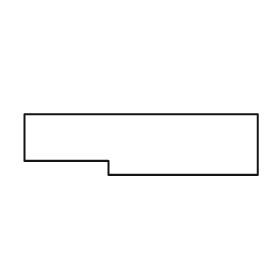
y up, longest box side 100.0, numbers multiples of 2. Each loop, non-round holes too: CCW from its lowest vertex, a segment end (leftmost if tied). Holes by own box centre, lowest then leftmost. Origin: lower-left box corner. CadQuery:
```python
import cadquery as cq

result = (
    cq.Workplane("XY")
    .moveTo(36.0, 0.0)
    .lineTo(100.0, 0.0)
    .lineTo(100.0, 26.0)
    .lineTo(0.0, 26.0)
    .lineTo(0.0, 6.0)
    .lineTo(36.0, 6.0)
    .close()
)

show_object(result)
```